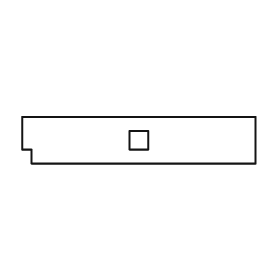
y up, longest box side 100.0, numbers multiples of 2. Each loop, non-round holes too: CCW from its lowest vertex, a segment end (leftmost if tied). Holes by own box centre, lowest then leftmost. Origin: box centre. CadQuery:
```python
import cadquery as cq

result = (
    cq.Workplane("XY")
    .moveTo(-46.0, -10.0)
    .lineTo(50.0, -10.0)
    .lineTo(50.0, 10.0)
    .lineTo(-50.0, 10.0)
    .lineTo(-50.0, -4.0)
    .lineTo(-46.0, -4.0)
    .close()
    .moveTo(-4.0, -4.0)
    .lineTo(4.0, -4.0)
    .lineTo(4.0, 4.0)
    .lineTo(-4.0, 4.0)
    .close()
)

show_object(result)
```